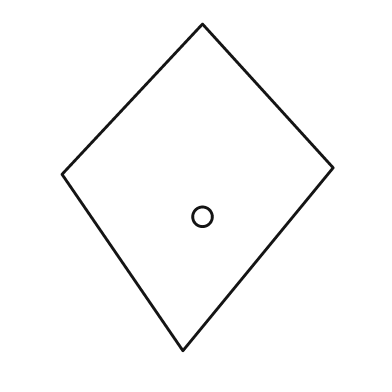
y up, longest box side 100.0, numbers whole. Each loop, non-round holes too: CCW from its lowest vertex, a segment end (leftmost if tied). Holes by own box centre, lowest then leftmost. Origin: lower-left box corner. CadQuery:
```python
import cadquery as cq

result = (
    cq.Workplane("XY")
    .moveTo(37.0, 0.0)
    .lineTo(83.0, 56.0)
    .lineTo(43.0, 100.0)
    .lineTo(0.0, 54.0)
    .close()
    .moveTo(43.0, 41.0)
    .circle(3.0)
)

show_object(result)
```